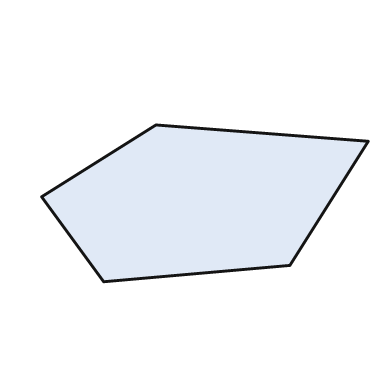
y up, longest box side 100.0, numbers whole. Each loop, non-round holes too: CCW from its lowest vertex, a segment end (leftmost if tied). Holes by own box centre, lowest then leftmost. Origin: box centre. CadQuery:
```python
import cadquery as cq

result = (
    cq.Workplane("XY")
    .moveTo(-31.0, -24.0)
    .lineTo(26.0, -19.0)
    .lineTo(50.0, 19.0)
    .lineTo(-15.0, 24.0)
    .lineTo(-50.0, 2.0)
    .close()
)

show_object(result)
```